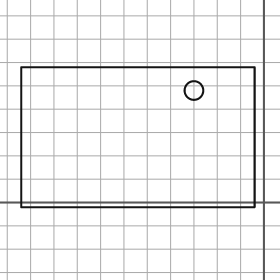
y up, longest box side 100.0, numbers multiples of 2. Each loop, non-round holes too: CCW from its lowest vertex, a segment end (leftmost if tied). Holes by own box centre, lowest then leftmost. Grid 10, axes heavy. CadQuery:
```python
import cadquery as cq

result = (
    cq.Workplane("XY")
    .moveTo(-104.0, -2.0)
    .lineTo(-4.0, -2.0)
    .lineTo(-4.0, 58.0)
    .lineTo(-104.0, 58.0)
    .close()
    .moveTo(-30.0, 48.0)
    .circle(4.0)
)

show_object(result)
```